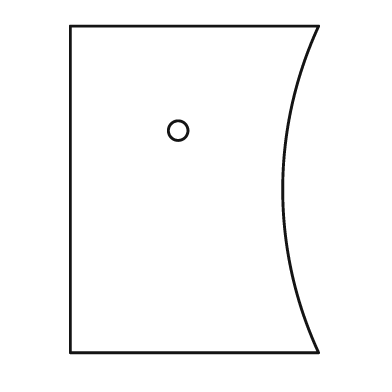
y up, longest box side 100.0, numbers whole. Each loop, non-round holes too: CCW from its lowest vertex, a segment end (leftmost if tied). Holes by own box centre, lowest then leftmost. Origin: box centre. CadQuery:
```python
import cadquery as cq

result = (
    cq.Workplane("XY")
    .moveTo(-38.0, -50.0)
    .lineTo(38.0, -50.0)
    .threePointArc((27.0, 0.0), (38.0, 50.0))
    .lineTo(-38.0, 50.0)
    .close()
    .moveTo(-5.0, 18.0)
    .circle(3.0)
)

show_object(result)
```